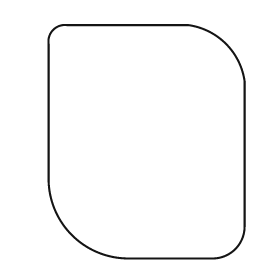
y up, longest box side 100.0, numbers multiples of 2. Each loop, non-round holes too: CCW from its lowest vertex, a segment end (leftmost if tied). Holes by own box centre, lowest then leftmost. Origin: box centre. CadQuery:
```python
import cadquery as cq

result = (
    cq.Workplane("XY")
    .moveTo(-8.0, -50.0)
    .lineTo(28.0, -50.0)
    .threePointArc((38.0, -46.0), (42.0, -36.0))
    .lineTo(42.0, 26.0)
    .threePointArc((34.0, 42.0), (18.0, 50.0))
    .lineTo(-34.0, 50.0)
    .threePointArc((-40.0, 48.0), (-42.0, 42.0))
    .lineTo(-42.0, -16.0)
    .threePointArc((-32.0, -40.0), (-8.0, -50.0))
    .close()
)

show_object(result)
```